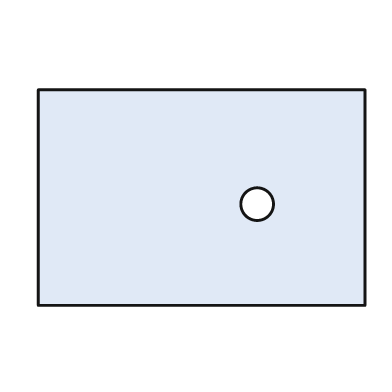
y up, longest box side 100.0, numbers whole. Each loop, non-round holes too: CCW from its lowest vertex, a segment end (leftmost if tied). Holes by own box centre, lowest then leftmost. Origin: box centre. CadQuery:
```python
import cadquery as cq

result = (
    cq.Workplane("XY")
    .moveTo(-50.0, -33.0)
    .lineTo(50.0, -33.0)
    .lineTo(50.0, 33.0)
    .lineTo(-50.0, 33.0)
    .close()
    .moveTo(17.0, -2.0)
    .circle(5.0)
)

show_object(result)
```